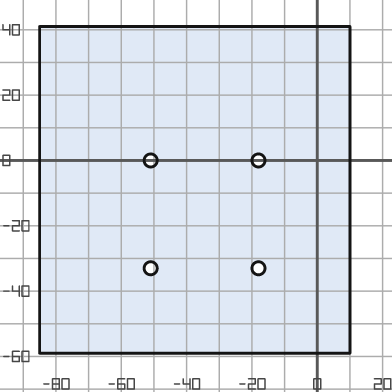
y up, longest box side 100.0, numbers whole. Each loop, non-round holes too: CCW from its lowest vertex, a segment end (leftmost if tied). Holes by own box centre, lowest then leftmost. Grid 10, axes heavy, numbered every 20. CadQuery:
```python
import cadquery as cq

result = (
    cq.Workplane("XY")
    .moveTo(-85.0, -59.0)
    .lineTo(10.0, -59.0)
    .lineTo(10.0, 41.0)
    .lineTo(-85.0, 41.0)
    .close()
    .moveTo(-51.0, -33.0)
    .circle(2.0)
    .moveTo(-18.0, -33.0)
    .circle(2.0)
    .moveTo(-51.0, 0.0)
    .circle(2.0)
    .moveTo(-18.0, 0.0)
    .circle(2.0)
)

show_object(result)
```